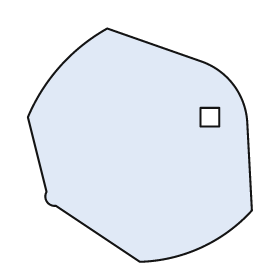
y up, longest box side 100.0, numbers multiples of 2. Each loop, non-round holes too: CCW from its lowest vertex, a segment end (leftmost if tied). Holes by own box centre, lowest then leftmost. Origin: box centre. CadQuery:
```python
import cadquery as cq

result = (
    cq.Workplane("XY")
    .moveTo(0.0, -50.0)
    .threePointArc((26.0, -44.0), (48.0, -28.0))
    .lineTo(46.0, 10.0)
    .threePointArc((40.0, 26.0), (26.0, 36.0))
    .lineTo(-14.0, 50.0)
    .threePointArc((-34.0, 34.0), (-48.0, 12.0))
    .lineTo(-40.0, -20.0)
    .threePointArc((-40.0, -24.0), (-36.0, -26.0))
    .close()
    .moveTo(26.0, 8.0)
    .lineTo(34.0, 8.0)
    .lineTo(34.0, 16.0)
    .lineTo(26.0, 16.0)
    .close()
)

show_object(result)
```